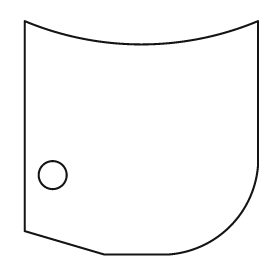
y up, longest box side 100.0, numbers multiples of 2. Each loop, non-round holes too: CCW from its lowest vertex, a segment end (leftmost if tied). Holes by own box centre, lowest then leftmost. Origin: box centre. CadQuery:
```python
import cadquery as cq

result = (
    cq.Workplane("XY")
    .moveTo(-16.0, -50.0)
    .lineTo(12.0, -50.0)
    .threePointArc((38.0, -38.0), (50.0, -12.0))
    .lineTo(50.0, 50.0)
    .threePointArc((0.0, 40.0), (-50.0, 50.0))
    .lineTo(-50.0, -40.0)
    .close()
    .moveTo(-38.0, -16.0)
    .circle(6.0)
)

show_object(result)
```